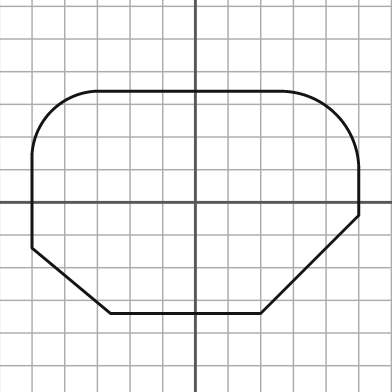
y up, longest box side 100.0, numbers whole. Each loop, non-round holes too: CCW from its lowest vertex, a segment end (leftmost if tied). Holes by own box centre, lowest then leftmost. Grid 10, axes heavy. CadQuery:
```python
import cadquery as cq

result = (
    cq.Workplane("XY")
    .moveTo(-26.0, -34.0)
    .lineTo(20.0, -34.0)
    .lineTo(50.0, -4.0)
    .lineTo(50.0, 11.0)
    .threePointArc((43.0, 27.0), (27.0, 34.0))
    .lineTo(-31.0, 34.0)
    .threePointArc((-44.0, 28.0), (-50.0, 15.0))
    .lineTo(-50.0, -14.0)
    .close()
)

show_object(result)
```